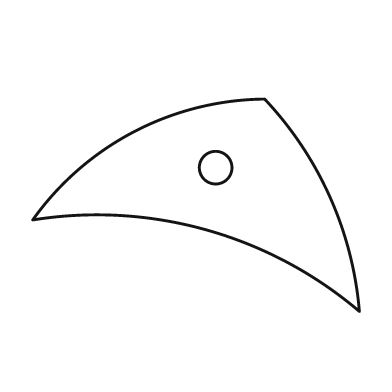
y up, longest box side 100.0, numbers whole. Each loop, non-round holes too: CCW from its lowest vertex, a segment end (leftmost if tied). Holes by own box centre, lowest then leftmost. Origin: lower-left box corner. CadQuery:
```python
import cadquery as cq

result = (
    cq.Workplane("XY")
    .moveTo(100.0, 0.0)
    .threePointArc((91.0, 35.0), (71.0, 65.0))
    .threePointArc((31.0, 55.0), (0.0, 28.0))
    .threePointArc((53.0, 25.0), (100.0, 0.0))
    .close()
    .moveTo(56.0, 44.0)
    .circle(5.0)
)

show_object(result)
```